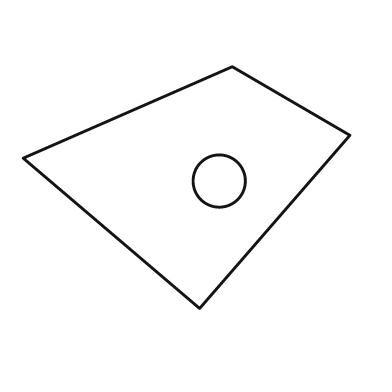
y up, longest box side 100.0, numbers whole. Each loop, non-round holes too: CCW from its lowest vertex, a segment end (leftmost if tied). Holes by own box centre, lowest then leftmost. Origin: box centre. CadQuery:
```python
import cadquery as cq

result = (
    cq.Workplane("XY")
    .moveTo(4.0, -37.0)
    .lineTo(50.0, 16.0)
    .lineTo(14.0, 37.0)
    .lineTo(-50.0, 9.0)
    .close()
    .moveTo(10.0, 2.0)
    .circle(8.0)
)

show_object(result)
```